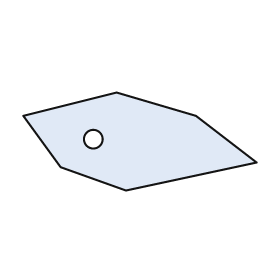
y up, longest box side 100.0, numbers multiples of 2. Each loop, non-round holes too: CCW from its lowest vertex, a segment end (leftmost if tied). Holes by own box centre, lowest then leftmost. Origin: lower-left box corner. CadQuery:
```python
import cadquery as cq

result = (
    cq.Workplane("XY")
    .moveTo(44.0, 0.0)
    .lineTo(100.0, 12.0)
    .lineTo(74.0, 32.0)
    .lineTo(40.0, 42.0)
    .lineTo(0.0, 32.0)
    .lineTo(16.0, 10.0)
    .close()
    .moveTo(30.0, 22.0)
    .circle(4.0)
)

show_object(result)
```